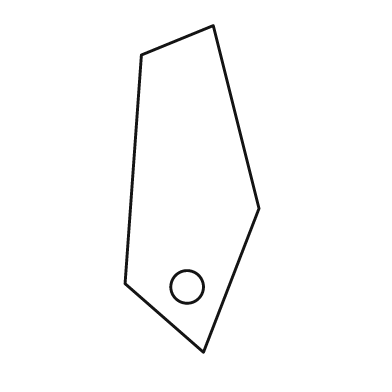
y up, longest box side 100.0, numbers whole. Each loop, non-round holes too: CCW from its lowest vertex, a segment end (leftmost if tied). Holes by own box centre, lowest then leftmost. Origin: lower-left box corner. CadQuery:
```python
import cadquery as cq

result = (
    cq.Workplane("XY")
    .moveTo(24.0, 0.0)
    .lineTo(41.0, 44.0)
    .lineTo(27.0, 100.0)
    .lineTo(5.0, 91.0)
    .lineTo(0.0, 21.0)
    .close()
    .moveTo(19.0, 20.0)
    .circle(5.0)
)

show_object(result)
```